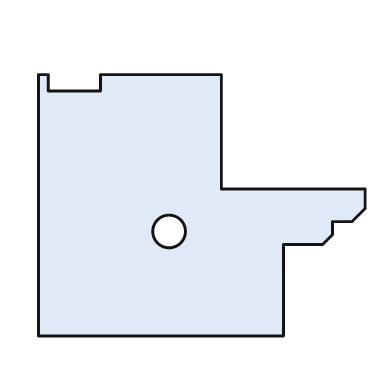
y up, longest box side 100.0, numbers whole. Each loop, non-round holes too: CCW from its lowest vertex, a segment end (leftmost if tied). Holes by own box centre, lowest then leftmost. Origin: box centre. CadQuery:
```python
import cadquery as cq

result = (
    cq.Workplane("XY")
    .moveTo(-50.0, -40.0)
    .lineTo(25.0, -40.0)
    .lineTo(25.0, -12.0)
    .lineTo(37.0, -12.0)
    .lineTo(40.0, -9.0)
    .lineTo(40.0, -5.0)
    .lineTo(46.0, -5.0)
    .lineTo(50.0, -1.0)
    .lineTo(50.0, 5.0)
    .lineTo(6.0, 5.0)
    .lineTo(6.0, 40.0)
    .lineTo(-31.0, 40.0)
    .lineTo(-31.0, 35.0)
    .lineTo(-47.0, 35.0)
    .lineTo(-47.0, 40.0)
    .lineTo(-50.0, 40.0)
    .close()
    .moveTo(-10.0, -8.0)
    .circle(5.0)
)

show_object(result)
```